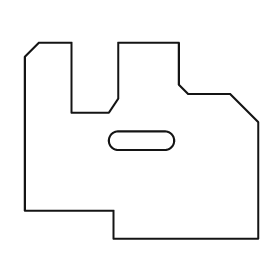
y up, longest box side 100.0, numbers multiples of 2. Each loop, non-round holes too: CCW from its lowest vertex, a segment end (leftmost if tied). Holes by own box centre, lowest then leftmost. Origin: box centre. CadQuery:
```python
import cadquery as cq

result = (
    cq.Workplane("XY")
    .moveTo(-12.0, -42.0)
    .lineTo(50.0, -42.0)
    .lineTo(50.0, 8.0)
    .lineTo(38.0, 20.0)
    .lineTo(20.0, 20.0)
    .lineTo(16.0, 24.0)
    .lineTo(16.0, 42.0)
    .lineTo(-10.0, 42.0)
    .lineTo(-10.0, 18.0)
    .lineTo(-14.0, 12.0)
    .lineTo(-30.0, 12.0)
    .lineTo(-30.0, 42.0)
    .lineTo(-44.0, 42.0)
    .lineTo(-50.0, 36.0)
    .lineTo(-50.0, -30.0)
    .lineTo(-12.0, -30.0)
    .close()
    .moveTo(-10.0, -4.0)
    .lineTo(10.0, -4.0)
    .threePointArc((14.0, 0.0), (10.0, 4.0))
    .lineTo(-10.0, 4.0)
    .threePointArc((-14.0, 0.0), (-10.0, -4.0))
    .close()
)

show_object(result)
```